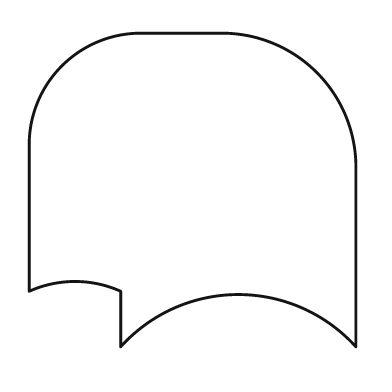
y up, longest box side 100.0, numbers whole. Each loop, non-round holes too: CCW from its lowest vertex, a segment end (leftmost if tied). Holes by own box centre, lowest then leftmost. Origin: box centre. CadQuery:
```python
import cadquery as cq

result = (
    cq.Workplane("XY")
    .moveTo(-22.0, -48.0)
    .threePointArc((14.0, -32.0), (50.0, -48.0))
    .lineTo(50.0, 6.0)
    .threePointArc((38.0, 36.0), (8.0, 48.0))
    .lineTo(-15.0, 48.0)
    .threePointArc((-40.0, 38.0), (-50.0, 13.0))
    .lineTo(-50.0, -31.0)
    .threePointArc((-36.0, -28.0), (-22.0, -31.0))
    .close()
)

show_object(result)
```